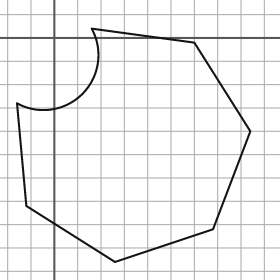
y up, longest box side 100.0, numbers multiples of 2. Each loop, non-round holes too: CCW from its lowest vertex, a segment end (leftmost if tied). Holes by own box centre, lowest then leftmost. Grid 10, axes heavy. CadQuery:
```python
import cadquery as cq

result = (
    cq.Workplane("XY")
    .moveTo(26.0, -96.0)
    .lineTo(68.0, -82.0)
    .lineTo(84.0, -40.0)
    .lineTo(60.0, -2.0)
    .lineTo(16.0, 4.0)
    .threePointArc((12.0, -24.0), (-16.0, -28.0))
    .lineTo(-12.0, -72.0)
    .close()
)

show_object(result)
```